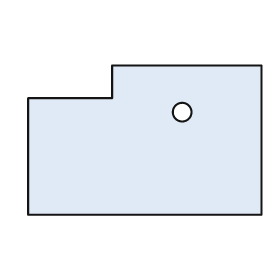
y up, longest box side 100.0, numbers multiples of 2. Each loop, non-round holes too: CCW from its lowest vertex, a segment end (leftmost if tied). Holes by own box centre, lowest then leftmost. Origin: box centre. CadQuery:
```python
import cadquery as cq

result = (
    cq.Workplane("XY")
    .moveTo(-50.0, -32.0)
    .lineTo(50.0, -32.0)
    .lineTo(50.0, 32.0)
    .lineTo(-14.0, 32.0)
    .lineTo(-14.0, 18.0)
    .lineTo(-50.0, 18.0)
    .close()
    .moveTo(16.0, 12.0)
    .circle(4.0)
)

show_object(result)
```